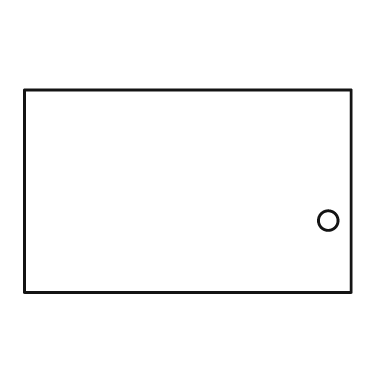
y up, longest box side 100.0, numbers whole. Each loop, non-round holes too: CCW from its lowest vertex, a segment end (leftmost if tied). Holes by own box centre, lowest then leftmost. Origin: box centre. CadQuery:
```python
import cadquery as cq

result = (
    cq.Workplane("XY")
    .moveTo(-50.0, -31.0)
    .lineTo(50.0, -31.0)
    .lineTo(50.0, 31.0)
    .lineTo(-50.0, 31.0)
    .close()
    .moveTo(43.0, -9.0)
    .circle(3.0)
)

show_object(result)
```